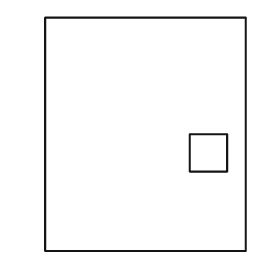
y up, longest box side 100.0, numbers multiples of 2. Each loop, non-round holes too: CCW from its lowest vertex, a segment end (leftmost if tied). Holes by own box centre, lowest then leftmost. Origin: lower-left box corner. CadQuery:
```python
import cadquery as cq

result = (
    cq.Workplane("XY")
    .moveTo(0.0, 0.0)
    .lineTo(86.0, 0.0)
    .lineTo(86.0, 100.0)
    .lineTo(0.0, 100.0)
    .close()
    .moveTo(62.0, 34.0)
    .lineTo(78.0, 34.0)
    .lineTo(78.0, 50.0)
    .lineTo(62.0, 50.0)
    .close()
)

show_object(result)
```